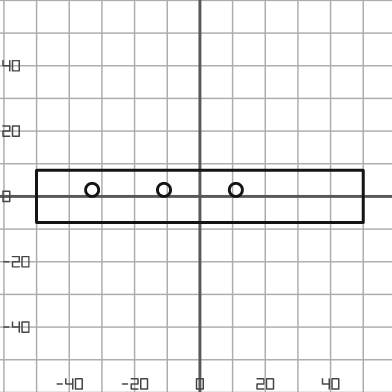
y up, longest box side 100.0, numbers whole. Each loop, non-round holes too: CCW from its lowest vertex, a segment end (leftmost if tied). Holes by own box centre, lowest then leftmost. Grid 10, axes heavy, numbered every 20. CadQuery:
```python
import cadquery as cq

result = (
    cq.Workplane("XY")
    .moveTo(-50.0, -8.0)
    .lineTo(50.0, -8.0)
    .lineTo(50.0, 8.0)
    .lineTo(-50.0, 8.0)
    .close()
    .moveTo(-33.0, 2.0)
    .circle(2.0)
    .moveTo(-11.0, 2.0)
    .circle(2.0)
    .moveTo(11.0, 2.0)
    .circle(2.0)
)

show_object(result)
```